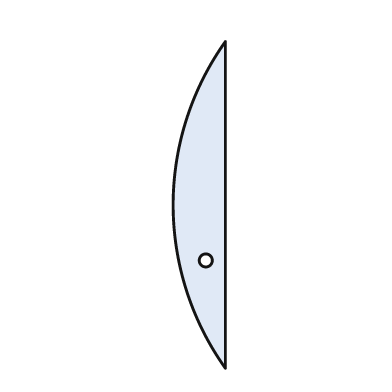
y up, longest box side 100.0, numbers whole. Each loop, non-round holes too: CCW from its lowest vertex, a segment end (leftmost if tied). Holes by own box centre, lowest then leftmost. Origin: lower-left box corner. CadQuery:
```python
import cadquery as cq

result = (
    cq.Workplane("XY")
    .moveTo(16.0, 0.0)
    .lineTo(16.0, 100.0)
    .threePointArc((0.0, 50.0), (16.0, 0.0))
    .close()
    .moveTo(10.0, 33.0)
    .circle(2.0)
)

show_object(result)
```